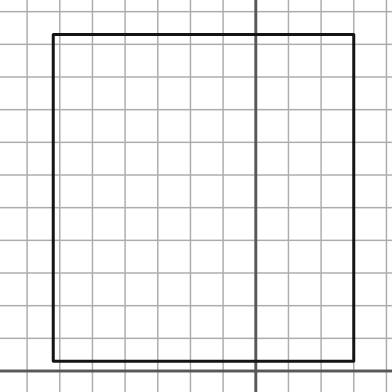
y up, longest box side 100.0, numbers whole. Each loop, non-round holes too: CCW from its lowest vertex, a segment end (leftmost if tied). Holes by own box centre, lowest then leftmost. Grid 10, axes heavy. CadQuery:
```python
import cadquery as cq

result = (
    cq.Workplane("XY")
    .moveTo(-62.0, 3.0)
    .lineTo(30.0, 3.0)
    .lineTo(30.0, 103.0)
    .lineTo(-62.0, 103.0)
    .close()
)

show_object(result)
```